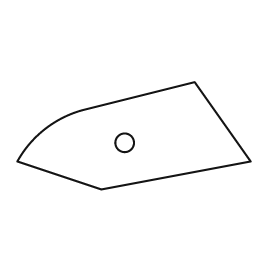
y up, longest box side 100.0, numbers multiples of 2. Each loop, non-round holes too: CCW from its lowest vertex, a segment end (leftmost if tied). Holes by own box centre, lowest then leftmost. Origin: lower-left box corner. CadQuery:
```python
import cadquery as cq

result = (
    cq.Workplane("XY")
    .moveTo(36.0, 0.0)
    .lineTo(100.0, 12.0)
    .lineTo(76.0, 46.0)
    .lineTo(28.0, 34.0)
    .threePointArc((12.0, 26.0), (0.0, 12.0))
    .close()
    .moveTo(46.0, 20.0)
    .circle(4.0)
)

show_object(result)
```